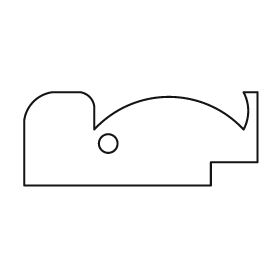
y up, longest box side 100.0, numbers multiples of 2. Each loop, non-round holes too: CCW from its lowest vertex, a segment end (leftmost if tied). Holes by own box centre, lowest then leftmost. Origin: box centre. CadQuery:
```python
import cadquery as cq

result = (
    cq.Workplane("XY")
    .moveTo(-50.0, -20.0)
    .lineTo(30.0, -20.0)
    .lineTo(30.0, -10.0)
    .lineTo(50.0, -10.0)
    .lineTo(50.0, 20.0)
    .lineTo(44.0, 20.0)
    .threePointArc((46.0, 12.0), (44.0, 4.0))
    .threePointArc((12.0, 18.0), (-20.0, 4.0))
    .lineTo(-20.0, 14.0)
    .threePointArc((-22.0, 18.0), (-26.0, 20.0))
    .lineTo(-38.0, 20.0)
    .threePointArc((-46.0, 16.0), (-50.0, 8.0))
    .close()
    .moveTo(-14.0, -2.0)
    .circle(4.0)
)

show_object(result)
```